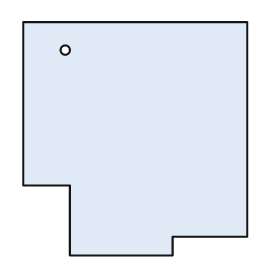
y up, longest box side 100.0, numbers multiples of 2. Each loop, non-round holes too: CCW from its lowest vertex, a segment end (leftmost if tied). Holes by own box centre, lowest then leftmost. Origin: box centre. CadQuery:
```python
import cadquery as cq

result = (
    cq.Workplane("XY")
    .moveTo(-28.0, -50.0)
    .lineTo(16.0, -50.0)
    .lineTo(16.0, -42.0)
    .lineTo(48.0, -42.0)
    .lineTo(48.0, 50.0)
    .lineTo(-48.0, 50.0)
    .lineTo(-48.0, -20.0)
    .lineTo(-28.0, -20.0)
    .close()
    .moveTo(-30.0, 38.0)
    .circle(2.0)
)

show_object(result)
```